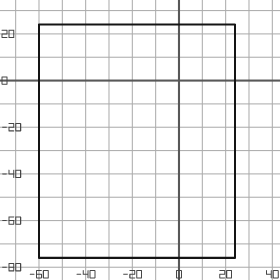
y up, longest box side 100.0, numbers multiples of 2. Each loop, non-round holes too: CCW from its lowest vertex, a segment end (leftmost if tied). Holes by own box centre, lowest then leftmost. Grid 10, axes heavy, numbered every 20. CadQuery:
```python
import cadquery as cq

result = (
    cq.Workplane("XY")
    .moveTo(-60.0, -76.0)
    .lineTo(24.0, -76.0)
    .lineTo(24.0, 24.0)
    .lineTo(-60.0, 24.0)
    .close()
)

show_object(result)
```